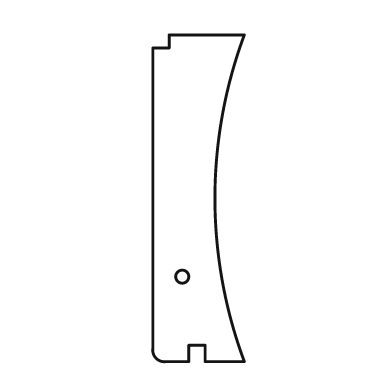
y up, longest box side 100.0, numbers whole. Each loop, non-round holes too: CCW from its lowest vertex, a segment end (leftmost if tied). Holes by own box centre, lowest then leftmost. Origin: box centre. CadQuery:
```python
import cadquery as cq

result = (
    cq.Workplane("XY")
    .moveTo(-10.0, -50.0)
    .lineTo(-3.0, -50.0)
    .lineTo(-3.0, -45.0)
    .lineTo(2.0, -45.0)
    .lineTo(2.0, -50.0)
    .lineTo(14.0, -50.0)
    .threePointArc((5.0, 0.0), (14.0, 50.0))
    .lineTo(-9.0, 50.0)
    .lineTo(-9.0, 46.0)
    .lineTo(-14.0, 46.0)
    .lineTo(-14.0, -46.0)
    .threePointArc((-13.0, -49.0), (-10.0, -50.0))
    .close()
    .moveTo(-5.0, -24.0)
    .circle(2.0)
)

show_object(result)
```